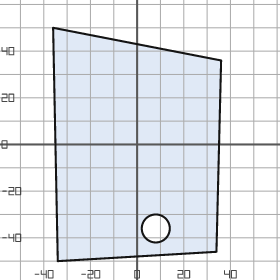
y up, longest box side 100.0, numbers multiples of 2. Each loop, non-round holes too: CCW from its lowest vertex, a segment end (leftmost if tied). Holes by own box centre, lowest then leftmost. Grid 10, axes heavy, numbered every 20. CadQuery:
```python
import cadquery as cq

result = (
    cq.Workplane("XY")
    .moveTo(-34.0, -50.0)
    .lineTo(34.0, -46.0)
    .lineTo(36.0, 36.0)
    .lineTo(-36.0, 50.0)
    .close()
    .moveTo(8.0, -36.0)
    .circle(6.0)
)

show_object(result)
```